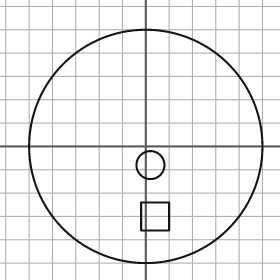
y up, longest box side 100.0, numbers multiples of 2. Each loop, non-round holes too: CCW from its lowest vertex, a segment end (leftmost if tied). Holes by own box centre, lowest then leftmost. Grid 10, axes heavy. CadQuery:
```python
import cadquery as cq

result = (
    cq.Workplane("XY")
    .moveTo(0.0, 0.0)
    .circle(50.0)
    .moveTo(-2.0, -36.0)
    .lineTo(10.0, -36.0)
    .lineTo(10.0, -24.0)
    .lineTo(-2.0, -24.0)
    .close()
    .moveTo(2.0, -8.0)
    .circle(6.0)
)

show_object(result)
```